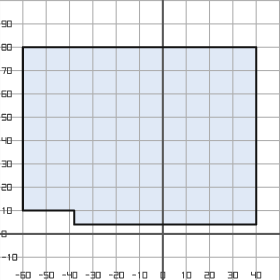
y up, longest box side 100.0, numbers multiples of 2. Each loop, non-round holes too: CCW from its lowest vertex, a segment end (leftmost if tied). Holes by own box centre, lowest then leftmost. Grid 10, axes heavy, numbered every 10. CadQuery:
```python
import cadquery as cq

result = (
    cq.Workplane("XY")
    .moveTo(-38.0, 4.0)
    .lineTo(40.0, 4.0)
    .lineTo(40.0, 80.0)
    .lineTo(-60.0, 80.0)
    .lineTo(-60.0, 10.0)
    .lineTo(-38.0, 10.0)
    .close()
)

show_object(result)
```